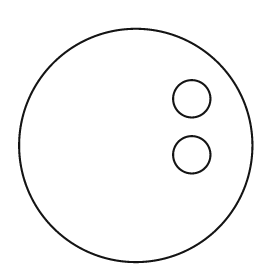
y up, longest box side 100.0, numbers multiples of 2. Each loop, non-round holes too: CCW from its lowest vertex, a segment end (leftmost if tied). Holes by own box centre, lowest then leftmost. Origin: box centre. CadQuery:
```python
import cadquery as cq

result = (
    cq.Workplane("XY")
    .moveTo(0.0, 0.0)
    .circle(50.0)
    .moveTo(24.0, -4.0)
    .circle(8.0)
    .moveTo(24.0, 20.0)
    .circle(8.0)
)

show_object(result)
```